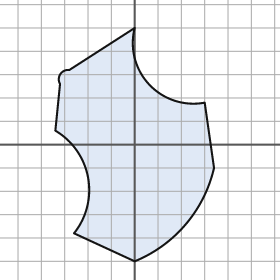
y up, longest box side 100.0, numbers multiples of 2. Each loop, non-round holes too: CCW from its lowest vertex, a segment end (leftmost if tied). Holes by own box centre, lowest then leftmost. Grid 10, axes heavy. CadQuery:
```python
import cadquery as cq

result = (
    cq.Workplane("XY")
    .moveTo(0.0, -50.0)
    .threePointArc((22.0, -34.0), (34.0, -10.0))
    .lineTo(30.0, 18.0)
    .threePointArc((6.0, 26.0), (0.0, 50.0))
    .lineTo(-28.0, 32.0)
    .threePointArc((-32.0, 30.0), (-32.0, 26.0))
    .lineTo(-34.0, 6.0)
    .threePointArc((-20.0, -14.0), (-26.0, -38.0))
    .close()
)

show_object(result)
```